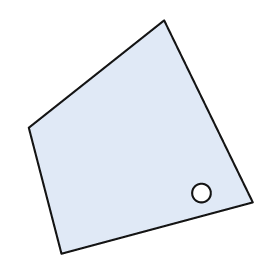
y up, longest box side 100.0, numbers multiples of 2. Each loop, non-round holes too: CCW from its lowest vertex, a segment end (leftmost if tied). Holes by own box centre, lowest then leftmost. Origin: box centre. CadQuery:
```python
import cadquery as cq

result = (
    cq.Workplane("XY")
    .moveTo(-34.0, -50.0)
    .lineTo(48.0, -28.0)
    .lineTo(10.0, 50.0)
    .lineTo(-48.0, 4.0)
    .close()
    .moveTo(26.0, -24.0)
    .circle(4.0)
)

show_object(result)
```